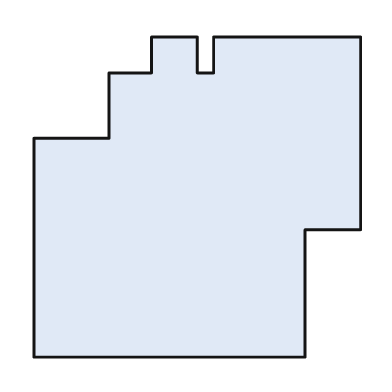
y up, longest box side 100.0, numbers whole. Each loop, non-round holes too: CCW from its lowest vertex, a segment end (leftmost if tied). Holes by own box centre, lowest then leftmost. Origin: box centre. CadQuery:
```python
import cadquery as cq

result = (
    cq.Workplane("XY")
    .moveTo(-50.0, -49.0)
    .lineTo(33.0, -49.0)
    .lineTo(33.0, -10.0)
    .lineTo(50.0, -10.0)
    .lineTo(50.0, 49.0)
    .lineTo(5.0, 49.0)
    .lineTo(5.0, 38.0)
    .lineTo(0.0, 38.0)
    .lineTo(0.0, 49.0)
    .lineTo(-14.0, 49.0)
    .lineTo(-14.0, 38.0)
    .lineTo(-27.0, 38.0)
    .lineTo(-27.0, 18.0)
    .lineTo(-50.0, 18.0)
    .close()
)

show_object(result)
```